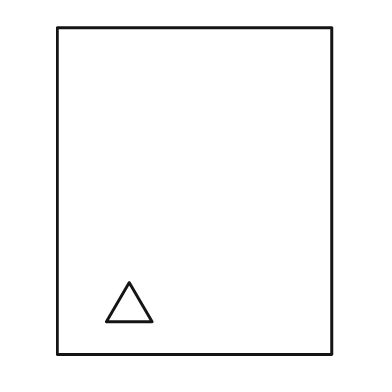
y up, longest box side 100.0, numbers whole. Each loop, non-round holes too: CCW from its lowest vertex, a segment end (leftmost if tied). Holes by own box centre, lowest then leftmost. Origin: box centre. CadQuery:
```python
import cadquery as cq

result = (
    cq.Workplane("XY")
    .moveTo(-42.0, -50.0)
    .lineTo(42.0, -50.0)
    .lineTo(42.0, 50.0)
    .lineTo(-42.0, 50.0)
    .close()
    .moveTo(-27.0, -40.0)
    .lineTo(-13.0, -40.0)
    .lineTo(-20.0, -28.0)
    .close()
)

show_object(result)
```